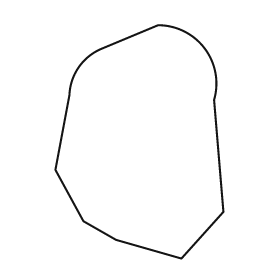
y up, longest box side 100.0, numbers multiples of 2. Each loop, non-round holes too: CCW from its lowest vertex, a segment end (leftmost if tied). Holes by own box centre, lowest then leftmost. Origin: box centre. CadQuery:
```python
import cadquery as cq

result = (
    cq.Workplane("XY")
    .moveTo(18.0, -50.0)
    .lineTo(36.0, -30.0)
    .lineTo(32.0, 18.0)
    .threePointArc((28.0, 40.0), (8.0, 50.0))
    .lineTo(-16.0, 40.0)
    .threePointArc((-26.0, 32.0), (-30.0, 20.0))
    .lineTo(-36.0, -12.0)
    .lineTo(-24.0, -34.0)
    .lineTo(-10.0, -42.0)
    .close()
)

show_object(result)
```